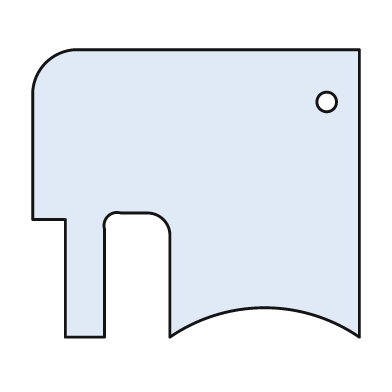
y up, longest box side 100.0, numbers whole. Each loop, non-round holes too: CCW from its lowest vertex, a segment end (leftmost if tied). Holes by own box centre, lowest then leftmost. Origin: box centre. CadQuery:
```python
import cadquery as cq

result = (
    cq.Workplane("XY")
    .moveTo(-40.0, -44.0)
    .lineTo(-28.0, -44.0)
    .lineTo(-28.0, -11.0)
    .threePointArc((-27.0, -7.0), (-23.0, -6.0))
    .lineTo(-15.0, -6.0)
    .threePointArc((-10.0, -8.0), (-8.0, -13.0))
    .lineTo(-8.0, -44.0)
    .threePointArc((21.0, -35.0), (50.0, -44.0))
    .lineTo(50.0, 44.0)
    .lineTo(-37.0, 44.0)
    .threePointArc((-46.0, 40.0), (-50.0, 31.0))
    .lineTo(-50.0, -8.0)
    .lineTo(-40.0, -8.0)
    .close()
    .moveTo(40.0, 28.0)
    .circle(3.0)
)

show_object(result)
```